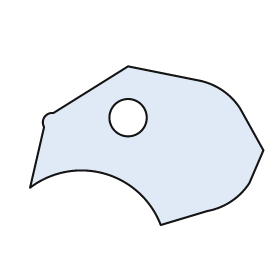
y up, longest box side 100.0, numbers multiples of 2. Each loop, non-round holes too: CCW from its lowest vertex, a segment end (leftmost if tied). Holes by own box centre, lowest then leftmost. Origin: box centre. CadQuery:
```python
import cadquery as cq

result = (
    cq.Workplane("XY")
    .moveTo(6.0, -34.0)
    .lineTo(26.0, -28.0)
    .threePointArc((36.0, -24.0), (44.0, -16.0))
    .lineTo(50.0, -2.0)
    .lineTo(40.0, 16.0)
    .threePointArc((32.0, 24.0), (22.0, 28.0))
    .lineTo(-8.0, 34.0)
    .lineTo(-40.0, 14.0)
    .threePointArc((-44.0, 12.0), (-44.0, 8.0))
    .lineTo(-50.0, -18.0)
    .threePointArc((-18.0, -12.0), (6.0, -34.0))
    .close()
    .moveTo(-8.0, 12.0)
    .circle(8.0)
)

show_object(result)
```